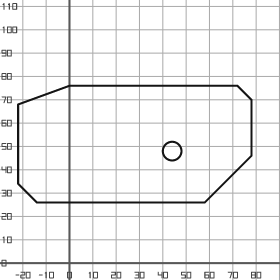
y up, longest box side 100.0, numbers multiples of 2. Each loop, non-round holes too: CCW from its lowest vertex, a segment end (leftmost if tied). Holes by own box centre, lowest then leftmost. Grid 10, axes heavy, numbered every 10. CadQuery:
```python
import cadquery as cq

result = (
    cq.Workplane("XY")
    .moveTo(-14.0, 26.0)
    .lineTo(58.0, 26.0)
    .lineTo(78.0, 46.0)
    .lineTo(78.0, 70.0)
    .lineTo(72.0, 76.0)
    .lineTo(0.0, 76.0)
    .lineTo(-22.0, 68.0)
    .lineTo(-22.0, 34.0)
    .close()
    .moveTo(44.0, 48.0)
    .circle(4.0)
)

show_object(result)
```